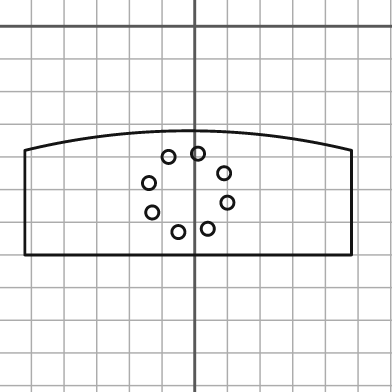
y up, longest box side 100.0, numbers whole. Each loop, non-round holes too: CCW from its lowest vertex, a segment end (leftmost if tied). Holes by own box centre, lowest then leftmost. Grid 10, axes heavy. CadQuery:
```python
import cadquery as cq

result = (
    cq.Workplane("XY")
    .moveTo(-52.0, -70.0)
    .lineTo(48.0, -70.0)
    .lineTo(48.0, -38.0)
    .threePointArc((-2.0, -32.0), (-52.0, -38.0))
    .close()
    .moveTo(-5.0, -63.0)
    .circle(2.0)
    .moveTo(4.0, -62.0)
    .circle(2.0)
    .moveTo(-13.0, -57.0)
    .circle(2.0)
    .moveTo(10.0, -54.0)
    .circle(2.0)
    .moveTo(-14.0, -48.0)
    .circle(2.0)
    .moveTo(9.0, -45.0)
    .circle(2.0)
    .moveTo(-8.0, -40.0)
    .circle(2.0)
    .moveTo(1.0, -39.0)
    .circle(2.0)
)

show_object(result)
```